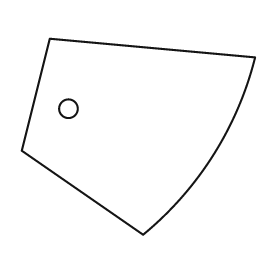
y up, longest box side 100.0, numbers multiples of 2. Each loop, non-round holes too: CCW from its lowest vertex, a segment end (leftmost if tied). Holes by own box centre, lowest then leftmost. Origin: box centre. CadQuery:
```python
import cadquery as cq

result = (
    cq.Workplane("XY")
    .moveTo(2.0, -42.0)
    .threePointArc((32.0, -8.0), (50.0, 34.0))
    .lineTo(-38.0, 42.0)
    .lineTo(-50.0, -6.0)
    .close()
    .moveTo(-30.0, 12.0)
    .circle(4.0)
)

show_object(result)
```